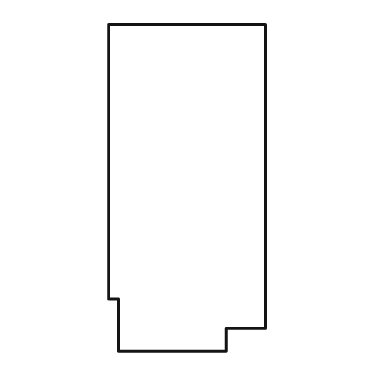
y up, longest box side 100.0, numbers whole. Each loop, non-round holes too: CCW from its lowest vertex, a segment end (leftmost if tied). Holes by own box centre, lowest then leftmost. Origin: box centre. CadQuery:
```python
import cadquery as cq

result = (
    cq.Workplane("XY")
    .moveTo(-21.0, -50.0)
    .lineTo(12.0, -50.0)
    .lineTo(12.0, -43.0)
    .lineTo(24.0, -43.0)
    .lineTo(24.0, 50.0)
    .lineTo(-24.0, 50.0)
    .lineTo(-24.0, -34.0)
    .lineTo(-21.0, -34.0)
    .close()
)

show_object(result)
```